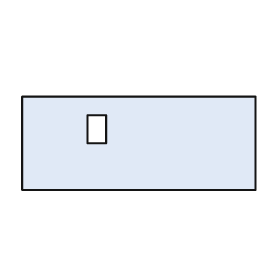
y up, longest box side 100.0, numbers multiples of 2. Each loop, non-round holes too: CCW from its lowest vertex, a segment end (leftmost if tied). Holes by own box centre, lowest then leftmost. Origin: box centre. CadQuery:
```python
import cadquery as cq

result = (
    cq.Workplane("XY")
    .moveTo(-50.0, -20.0)
    .lineTo(50.0, -20.0)
    .lineTo(50.0, 20.0)
    .lineTo(-50.0, 20.0)
    .close()
    .moveTo(-22.0, 0.0)
    .lineTo(-14.0, 0.0)
    .lineTo(-14.0, 12.0)
    .lineTo(-22.0, 12.0)
    .close()
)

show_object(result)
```